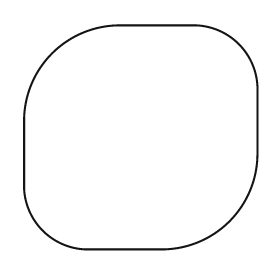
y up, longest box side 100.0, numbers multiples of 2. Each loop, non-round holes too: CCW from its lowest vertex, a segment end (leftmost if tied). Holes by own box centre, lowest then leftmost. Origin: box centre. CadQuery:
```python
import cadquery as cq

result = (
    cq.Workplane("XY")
    .moveTo(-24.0, -48.0)
    .lineTo(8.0, -48.0)
    .threePointArc((38.0, -36.0), (50.0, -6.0))
    .lineTo(50.0, 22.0)
    .threePointArc((42.0, 40.0), (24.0, 48.0))
    .lineTo(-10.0, 48.0)
    .threePointArc((-38.0, 36.0), (-50.0, 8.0))
    .lineTo(-50.0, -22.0)
    .threePointArc((-42.0, -40.0), (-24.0, -48.0))
    .close()
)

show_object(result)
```